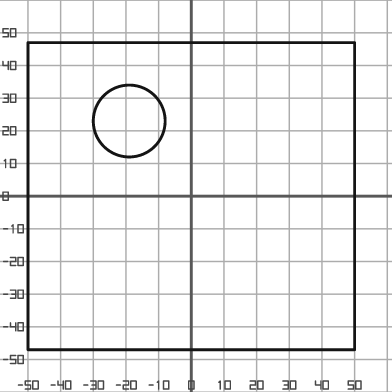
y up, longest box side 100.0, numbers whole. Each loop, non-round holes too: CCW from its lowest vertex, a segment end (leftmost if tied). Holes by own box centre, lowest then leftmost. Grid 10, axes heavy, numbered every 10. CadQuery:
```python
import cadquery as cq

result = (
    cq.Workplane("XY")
    .moveTo(-50.0, -47.0)
    .lineTo(50.0, -47.0)
    .lineTo(50.0, 47.0)
    .lineTo(-50.0, 47.0)
    .close()
    .moveTo(-19.0, 23.0)
    .circle(11.0)
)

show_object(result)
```